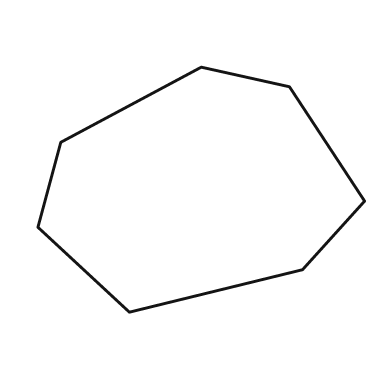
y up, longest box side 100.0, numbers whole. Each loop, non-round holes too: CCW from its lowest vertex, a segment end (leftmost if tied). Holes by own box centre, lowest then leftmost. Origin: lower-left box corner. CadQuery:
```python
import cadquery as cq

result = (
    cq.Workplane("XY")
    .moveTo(28.0, 0.0)
    .lineTo(81.0, 13.0)
    .lineTo(100.0, 34.0)
    .lineTo(77.0, 69.0)
    .lineTo(50.0, 75.0)
    .lineTo(7.0, 52.0)
    .lineTo(0.0, 26.0)
    .close()
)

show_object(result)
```